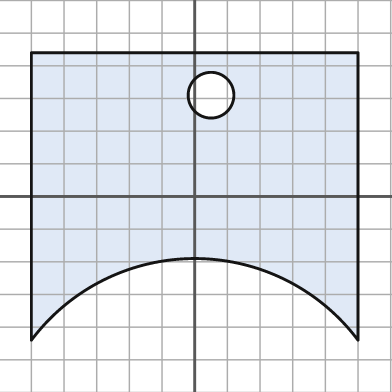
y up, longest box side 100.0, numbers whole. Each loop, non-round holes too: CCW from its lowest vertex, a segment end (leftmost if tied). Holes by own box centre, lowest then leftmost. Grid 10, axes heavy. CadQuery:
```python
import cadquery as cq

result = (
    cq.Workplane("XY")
    .moveTo(-50.0, -44.0)
    .threePointArc((0.0, -19.0), (50.0, -44.0))
    .lineTo(50.0, 44.0)
    .lineTo(-50.0, 44.0)
    .close()
    .moveTo(5.0, 31.0)
    .circle(7.0)
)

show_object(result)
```